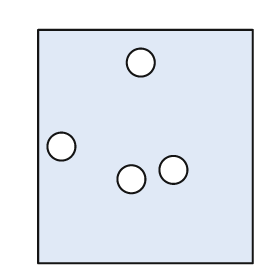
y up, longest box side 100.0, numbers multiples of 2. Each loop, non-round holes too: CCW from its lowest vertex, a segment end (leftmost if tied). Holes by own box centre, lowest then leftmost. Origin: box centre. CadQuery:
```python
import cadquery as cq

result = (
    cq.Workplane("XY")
    .moveTo(-46.0, -50.0)
    .lineTo(46.0, -50.0)
    .lineTo(46.0, 50.0)
    .lineTo(-46.0, 50.0)
    .close()
    .moveTo(-6.0, -14.0)
    .circle(6.0)
    .moveTo(12.0, -10.0)
    .circle(6.0)
    .moveTo(-36.0, 0.0)
    .circle(6.0)
    .moveTo(-2.0, 36.0)
    .circle(6.0)
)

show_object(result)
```